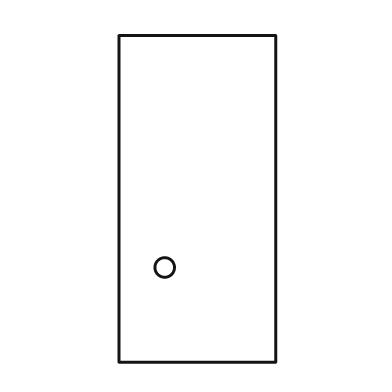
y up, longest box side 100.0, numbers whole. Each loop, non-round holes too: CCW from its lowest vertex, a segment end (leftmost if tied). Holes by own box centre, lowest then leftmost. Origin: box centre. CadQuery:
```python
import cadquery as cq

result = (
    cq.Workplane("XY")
    .moveTo(-24.0, -50.0)
    .lineTo(24.0, -50.0)
    .lineTo(24.0, 50.0)
    .lineTo(-24.0, 50.0)
    .close()
    .moveTo(-10.0, -21.0)
    .circle(3.0)
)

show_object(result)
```